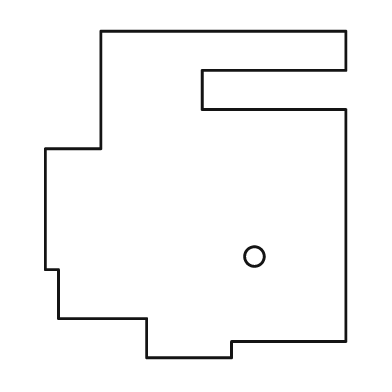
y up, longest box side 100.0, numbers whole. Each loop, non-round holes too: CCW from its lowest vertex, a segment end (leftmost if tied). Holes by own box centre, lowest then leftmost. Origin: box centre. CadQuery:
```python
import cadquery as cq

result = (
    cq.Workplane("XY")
    .moveTo(-15.0, -50.0)
    .lineTo(11.0, -50.0)
    .lineTo(11.0, -45.0)
    .lineTo(46.0, -45.0)
    .lineTo(46.0, 26.0)
    .lineTo(2.0, 26.0)
    .lineTo(2.0, 38.0)
    .lineTo(46.0, 38.0)
    .lineTo(46.0, 50.0)
    .lineTo(-29.0, 50.0)
    .lineTo(-29.0, 14.0)
    .lineTo(-46.0, 14.0)
    .lineTo(-46.0, -23.0)
    .lineTo(-42.0, -23.0)
    .lineTo(-42.0, -38.0)
    .lineTo(-15.0, -38.0)
    .close()
    .moveTo(18.0, -19.0)
    .circle(3.0)
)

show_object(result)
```